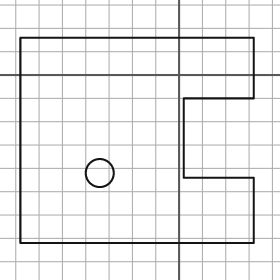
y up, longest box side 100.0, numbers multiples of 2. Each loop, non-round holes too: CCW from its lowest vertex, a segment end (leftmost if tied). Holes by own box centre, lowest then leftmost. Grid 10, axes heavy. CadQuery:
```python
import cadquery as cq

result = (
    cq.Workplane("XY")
    .moveTo(-68.0, -72.0)
    .lineTo(32.0, -72.0)
    .lineTo(32.0, -44.0)
    .lineTo(2.0, -44.0)
    .lineTo(2.0, -10.0)
    .lineTo(32.0, -10.0)
    .lineTo(32.0, 16.0)
    .lineTo(-68.0, 16.0)
    .close()
    .moveTo(-34.0, -42.0)
    .circle(6.0)
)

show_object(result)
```